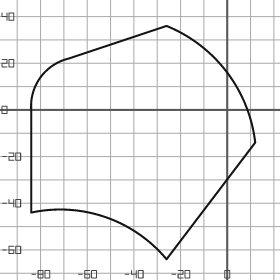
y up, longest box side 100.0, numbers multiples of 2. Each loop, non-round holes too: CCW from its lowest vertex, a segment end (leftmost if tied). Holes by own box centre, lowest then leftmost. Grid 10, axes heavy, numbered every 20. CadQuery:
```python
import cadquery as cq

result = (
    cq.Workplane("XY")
    .moveTo(-26.0, -64.0)
    .lineTo(12.0, -14.0)
    .threePointArc((0.0, 16.0), (-26.0, 36.0))
    .lineTo(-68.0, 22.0)
    .threePointArc((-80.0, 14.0), (-84.0, 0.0))
    .lineTo(-84.0, -44.0)
    .threePointArc((-52.0, -46.0), (-26.0, -64.0))
    .close()
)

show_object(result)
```